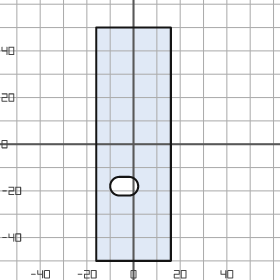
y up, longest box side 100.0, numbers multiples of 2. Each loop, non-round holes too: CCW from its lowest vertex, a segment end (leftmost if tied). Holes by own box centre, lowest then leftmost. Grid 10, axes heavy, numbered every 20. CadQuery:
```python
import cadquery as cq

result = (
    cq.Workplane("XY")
    .moveTo(-16.0, -50.0)
    .lineTo(16.0, -50.0)
    .lineTo(16.0, 50.0)
    .lineTo(-16.0, 50.0)
    .close()
    .moveTo(-6.0, -22.0)
    .lineTo(-2.0, -22.0)
    .threePointArc((2.0, -18.0), (-2.0, -14.0))
    .lineTo(-6.0, -14.0)
    .threePointArc((-10.0, -18.0), (-6.0, -22.0))
    .close()
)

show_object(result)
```